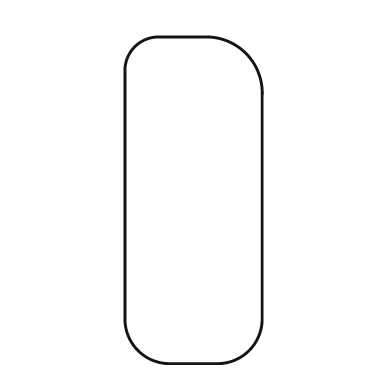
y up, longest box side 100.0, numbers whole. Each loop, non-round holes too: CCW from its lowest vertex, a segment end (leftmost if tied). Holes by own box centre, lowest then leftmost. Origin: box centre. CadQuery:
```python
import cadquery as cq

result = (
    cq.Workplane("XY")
    .moveTo(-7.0, -50.0)
    .lineTo(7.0, -50.0)
    .threePointArc((17.0, -46.0), (21.0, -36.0))
    .lineTo(21.0, 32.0)
    .threePointArc((16.0, 45.0), (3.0, 50.0))
    .lineTo(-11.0, 50.0)
    .threePointArc((-18.0, 47.0), (-21.0, 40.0))
    .lineTo(-21.0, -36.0)
    .threePointArc((-17.0, -46.0), (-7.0, -50.0))
    .close()
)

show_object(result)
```